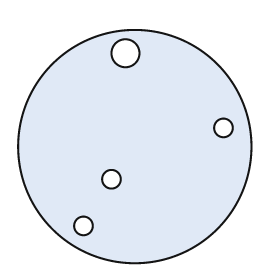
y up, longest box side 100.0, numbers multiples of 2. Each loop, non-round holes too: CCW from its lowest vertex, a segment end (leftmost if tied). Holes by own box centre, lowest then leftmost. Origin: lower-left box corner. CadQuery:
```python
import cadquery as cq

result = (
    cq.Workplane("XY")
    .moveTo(50.0, 50.0)
    .circle(50.0)
    .moveTo(28.0, 16.0)
    .circle(4.0)
    .moveTo(40.0, 36.0)
    .circle(4.0)
    .moveTo(88.0, 58.0)
    .circle(4.0)
    .moveTo(46.0, 90.0)
    .circle(6.0)
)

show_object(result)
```